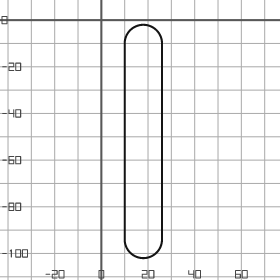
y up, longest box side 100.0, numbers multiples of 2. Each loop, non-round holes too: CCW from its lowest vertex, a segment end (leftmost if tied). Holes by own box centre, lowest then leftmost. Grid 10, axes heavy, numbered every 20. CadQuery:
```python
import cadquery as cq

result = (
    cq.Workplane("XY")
    .moveTo(10.0, -94.0)
    .threePointArc((18.0, -102.0), (26.0, -94.0))
    .lineTo(26.0, -10.0)
    .threePointArc((18.0, -2.0), (10.0, -10.0))
    .close()
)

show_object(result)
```